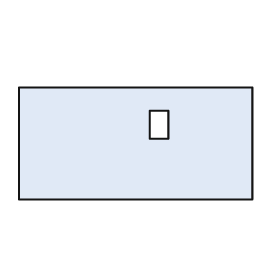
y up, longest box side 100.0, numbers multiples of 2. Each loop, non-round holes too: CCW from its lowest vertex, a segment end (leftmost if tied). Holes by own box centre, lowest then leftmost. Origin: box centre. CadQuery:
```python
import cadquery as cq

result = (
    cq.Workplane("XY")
    .moveTo(-50.0, -24.0)
    .lineTo(50.0, -24.0)
    .lineTo(50.0, 24.0)
    .lineTo(-50.0, 24.0)
    .close()
    .moveTo(6.0, 2.0)
    .lineTo(14.0, 2.0)
    .lineTo(14.0, 14.0)
    .lineTo(6.0, 14.0)
    .close()
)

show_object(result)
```